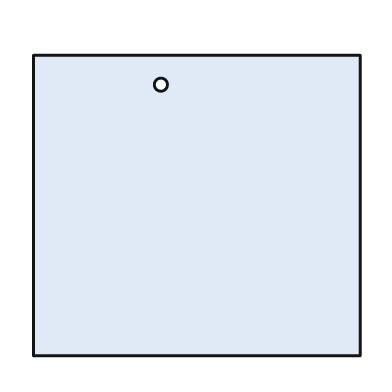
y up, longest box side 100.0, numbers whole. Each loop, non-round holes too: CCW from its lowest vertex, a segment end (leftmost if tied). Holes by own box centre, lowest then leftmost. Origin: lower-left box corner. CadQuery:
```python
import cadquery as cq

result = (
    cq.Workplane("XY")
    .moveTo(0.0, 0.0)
    .lineTo(100.0, 0.0)
    .lineTo(100.0, 92.0)
    .lineTo(0.0, 92.0)
    .close()
    .moveTo(39.0, 83.0)
    .circle(2.0)
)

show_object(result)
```